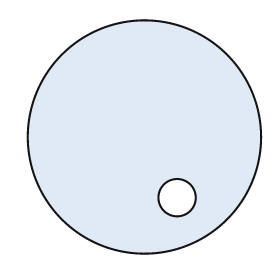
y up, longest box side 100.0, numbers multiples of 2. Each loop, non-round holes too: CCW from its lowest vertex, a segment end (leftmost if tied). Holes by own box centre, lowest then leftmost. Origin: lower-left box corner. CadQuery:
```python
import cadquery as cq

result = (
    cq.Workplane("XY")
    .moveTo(50.0, 50.0)
    .circle(50.0)
    .moveTo(64.0, 24.0)
    .circle(8.0)
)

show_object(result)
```